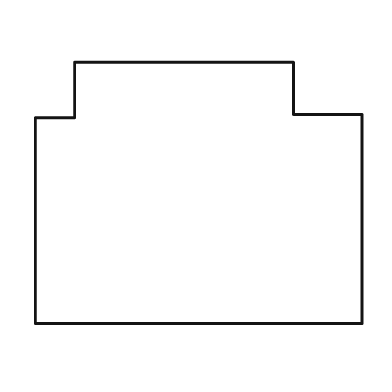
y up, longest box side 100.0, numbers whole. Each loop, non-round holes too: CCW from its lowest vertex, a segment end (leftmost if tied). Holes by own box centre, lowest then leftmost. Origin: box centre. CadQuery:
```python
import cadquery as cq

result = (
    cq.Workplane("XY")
    .moveTo(-50.0, -40.0)
    .lineTo(50.0, -40.0)
    .lineTo(50.0, 24.0)
    .lineTo(29.0, 24.0)
    .lineTo(29.0, 40.0)
    .lineTo(-38.0, 40.0)
    .lineTo(-38.0, 23.0)
    .lineTo(-50.0, 23.0)
    .close()
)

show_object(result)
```